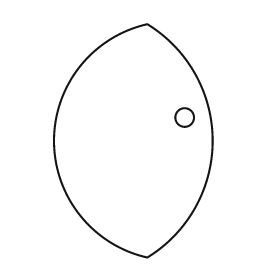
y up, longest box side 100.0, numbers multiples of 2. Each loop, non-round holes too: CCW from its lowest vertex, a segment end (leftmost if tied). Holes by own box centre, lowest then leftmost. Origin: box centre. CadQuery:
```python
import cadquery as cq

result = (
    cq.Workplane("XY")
    .moveTo(6.0, -50.0)
    .threePointArc((34.0, 0.0), (6.0, 50.0))
    .threePointArc((-34.0, 0.0), (6.0, -50.0))
    .close()
    .moveTo(22.0, 10.0)
    .circle(4.0)
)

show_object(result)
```